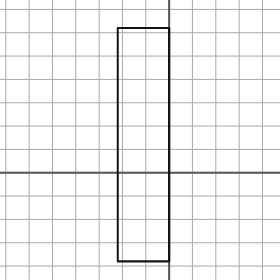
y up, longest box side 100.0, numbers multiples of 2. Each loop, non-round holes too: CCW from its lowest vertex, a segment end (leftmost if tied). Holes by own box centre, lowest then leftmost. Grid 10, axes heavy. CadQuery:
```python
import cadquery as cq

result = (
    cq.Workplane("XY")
    .moveTo(-22.0, -38.0)
    .lineTo(0.0, -38.0)
    .lineTo(0.0, 62.0)
    .lineTo(-22.0, 62.0)
    .close()
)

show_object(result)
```